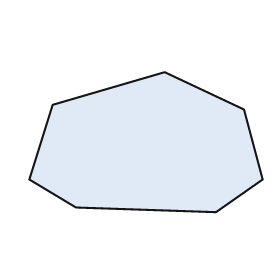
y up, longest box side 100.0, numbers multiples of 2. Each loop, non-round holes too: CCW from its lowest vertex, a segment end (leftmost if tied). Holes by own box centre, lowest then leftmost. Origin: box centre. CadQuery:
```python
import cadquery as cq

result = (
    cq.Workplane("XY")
    .moveTo(30.0, -30.0)
    .lineTo(50.0, -16.0)
    .lineTo(42.0, 14.0)
    .lineTo(8.0, 30.0)
    .lineTo(-40.0, 16.0)
    .lineTo(-50.0, -16.0)
    .lineTo(-30.0, -28.0)
    .close()
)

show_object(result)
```